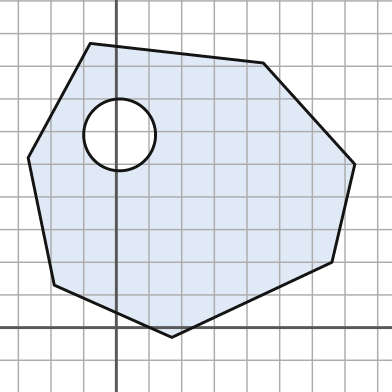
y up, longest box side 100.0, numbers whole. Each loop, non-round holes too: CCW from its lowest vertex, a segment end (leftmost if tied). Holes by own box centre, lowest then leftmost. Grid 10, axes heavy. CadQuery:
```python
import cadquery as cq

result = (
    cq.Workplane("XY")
    .moveTo(17.0, -3.0)
    .lineTo(66.0, 20.0)
    .lineTo(73.0, 50.0)
    .lineTo(45.0, 81.0)
    .lineTo(-8.0, 87.0)
    .lineTo(-27.0, 52.0)
    .lineTo(-19.0, 13.0)
    .close()
    .moveTo(1.0, 59.0)
    .circle(11.0)
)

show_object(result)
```